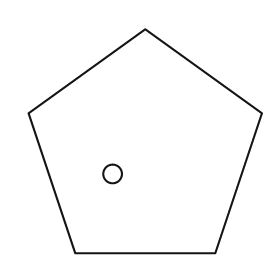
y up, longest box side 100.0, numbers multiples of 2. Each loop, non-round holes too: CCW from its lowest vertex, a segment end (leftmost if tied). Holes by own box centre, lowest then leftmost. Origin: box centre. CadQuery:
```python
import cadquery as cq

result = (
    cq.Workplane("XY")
    .moveTo(-30.0, -48.0)
    .lineTo(30.0, -48.0)
    .lineTo(50.0, 12.0)
    .lineTo(0.0, 48.0)
    .lineTo(-50.0, 12.0)
    .close()
    .moveTo(-14.0, -14.0)
    .circle(4.0)
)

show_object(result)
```